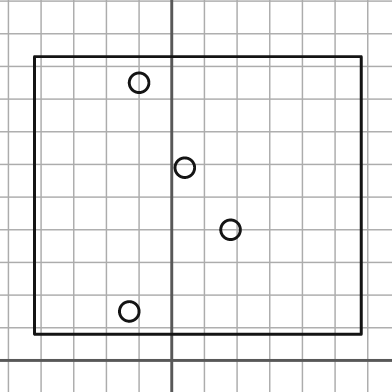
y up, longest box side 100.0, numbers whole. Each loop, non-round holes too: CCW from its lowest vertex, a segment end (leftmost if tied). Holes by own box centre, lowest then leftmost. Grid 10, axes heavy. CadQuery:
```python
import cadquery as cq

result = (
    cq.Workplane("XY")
    .moveTo(-42.0, 8.0)
    .lineTo(58.0, 8.0)
    .lineTo(58.0, 93.0)
    .lineTo(-42.0, 93.0)
    .close()
    .moveTo(-13.0, 15.0)
    .circle(3.0)
    .moveTo(18.0, 40.0)
    .circle(3.0)
    .moveTo(4.0, 59.0)
    .circle(3.0)
    .moveTo(-10.0, 85.0)
    .circle(3.0)
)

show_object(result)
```